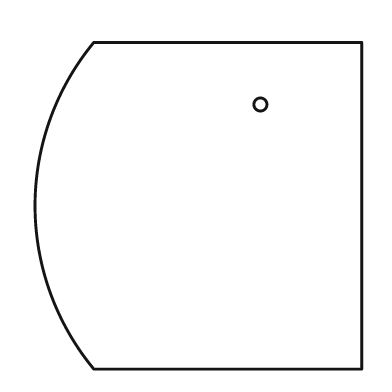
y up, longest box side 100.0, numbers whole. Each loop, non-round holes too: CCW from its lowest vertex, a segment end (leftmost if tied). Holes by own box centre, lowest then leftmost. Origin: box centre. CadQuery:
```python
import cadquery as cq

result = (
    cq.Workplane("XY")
    .moveTo(-32.0, -50.0)
    .lineTo(50.0, -50.0)
    .lineTo(50.0, 50.0)
    .lineTo(-32.0, 50.0)
    .threePointArc((-50.0, 0.0), (-32.0, -50.0))
    .close()
    .moveTo(19.0, 31.0)
    .circle(2.0)
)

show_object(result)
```